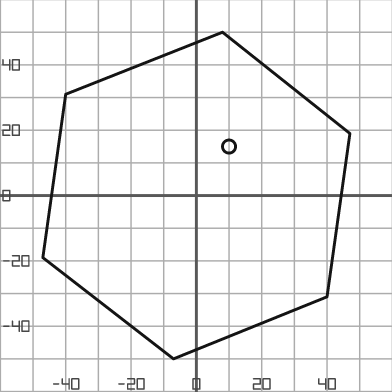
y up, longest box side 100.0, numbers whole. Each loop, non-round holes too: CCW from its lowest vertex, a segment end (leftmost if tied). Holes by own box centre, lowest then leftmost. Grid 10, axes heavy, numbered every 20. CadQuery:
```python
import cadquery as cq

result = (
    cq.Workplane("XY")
    .moveTo(-7.0, -50.0)
    .lineTo(40.0, -31.0)
    .lineTo(47.0, 19.0)
    .lineTo(8.0, 50.0)
    .lineTo(-40.0, 31.0)
    .lineTo(-47.0, -19.0)
    .close()
    .moveTo(10.0, 15.0)
    .circle(2.0)
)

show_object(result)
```